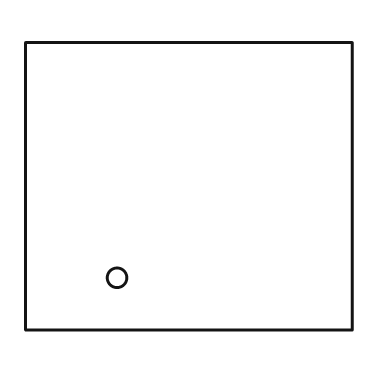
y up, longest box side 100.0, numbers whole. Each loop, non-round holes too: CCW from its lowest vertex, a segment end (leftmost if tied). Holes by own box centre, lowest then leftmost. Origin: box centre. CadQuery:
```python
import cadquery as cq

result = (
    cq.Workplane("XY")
    .moveTo(-50.0, -44.0)
    .lineTo(50.0, -44.0)
    .lineTo(50.0, 44.0)
    .lineTo(-50.0, 44.0)
    .close()
    .moveTo(-22.0, -28.0)
    .circle(3.0)
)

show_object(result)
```